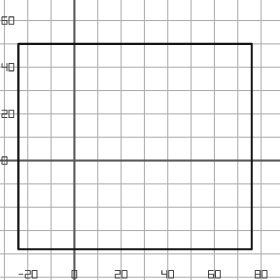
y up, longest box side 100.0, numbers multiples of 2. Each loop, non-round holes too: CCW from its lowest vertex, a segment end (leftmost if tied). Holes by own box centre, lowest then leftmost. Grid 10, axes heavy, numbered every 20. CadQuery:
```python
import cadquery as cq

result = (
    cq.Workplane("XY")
    .moveTo(-24.0, -38.0)
    .lineTo(76.0, -38.0)
    .lineTo(76.0, 50.0)
    .lineTo(-24.0, 50.0)
    .close()
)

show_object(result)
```